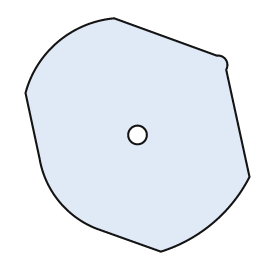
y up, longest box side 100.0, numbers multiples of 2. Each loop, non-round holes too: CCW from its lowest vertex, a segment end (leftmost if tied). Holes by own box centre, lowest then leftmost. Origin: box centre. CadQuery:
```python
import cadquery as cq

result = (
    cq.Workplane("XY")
    .moveTo(10.0, -50.0)
    .threePointArc((32.0, -38.0), (48.0, -18.0))
    .lineTo(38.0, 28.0)
    .threePointArc((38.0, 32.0), (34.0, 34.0))
    .lineTo(-10.0, 50.0)
    .threePointArc((-34.0, 40.0), (-48.0, 18.0))
    .lineTo(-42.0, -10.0)
    .threePointArc((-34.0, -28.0), (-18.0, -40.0))
    .close()
    .moveTo(0.0, 0.0)
    .circle(4.0)
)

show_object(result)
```